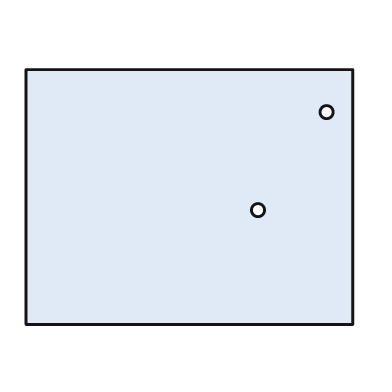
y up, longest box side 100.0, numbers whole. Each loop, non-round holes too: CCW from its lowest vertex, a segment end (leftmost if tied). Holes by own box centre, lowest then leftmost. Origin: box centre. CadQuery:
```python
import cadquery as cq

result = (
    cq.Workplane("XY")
    .moveTo(-50.0, -39.0)
    .lineTo(50.0, -39.0)
    .lineTo(50.0, 39.0)
    .lineTo(-50.0, 39.0)
    .close()
    .moveTo(21.0, -4.0)
    .circle(2.0)
    .moveTo(42.0, 26.0)
    .circle(2.0)
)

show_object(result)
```